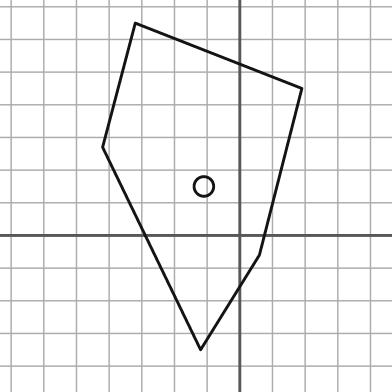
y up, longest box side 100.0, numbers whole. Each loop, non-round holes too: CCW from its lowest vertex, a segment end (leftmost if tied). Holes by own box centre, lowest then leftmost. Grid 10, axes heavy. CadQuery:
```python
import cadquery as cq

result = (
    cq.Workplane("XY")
    .moveTo(-12.0, -35.0)
    .lineTo(6.0, -6.0)
    .lineTo(19.0, 45.0)
    .lineTo(-32.0, 65.0)
    .lineTo(-42.0, 27.0)
    .close()
    .moveTo(-11.0, 15.0)
    .circle(3.0)
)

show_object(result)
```